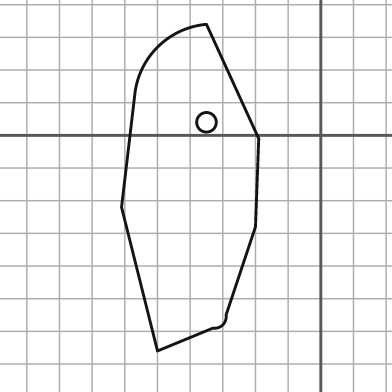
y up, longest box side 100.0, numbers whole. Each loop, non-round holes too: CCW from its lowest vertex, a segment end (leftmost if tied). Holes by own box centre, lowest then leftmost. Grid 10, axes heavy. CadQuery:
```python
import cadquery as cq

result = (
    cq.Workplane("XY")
    .moveTo(-50.0, -66.0)
    .lineTo(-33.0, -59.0)
    .threePointArc((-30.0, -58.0), (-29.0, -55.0))
    .lineTo(-20.0, -28.0)
    .lineTo(-19.0, -1.0)
    .lineTo(-35.0, 34.0)
    .threePointArc((-50.0, 27.0), (-57.0, 12.0))
    .lineTo(-61.0, -22.0)
    .close()
    .moveTo(-35.0, 4.0)
    .circle(3.0)
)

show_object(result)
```